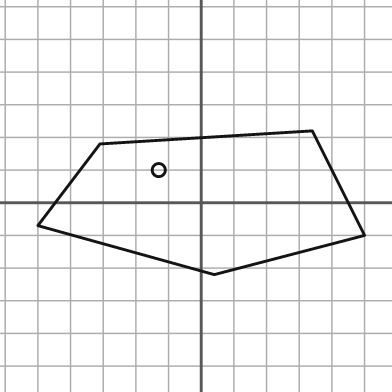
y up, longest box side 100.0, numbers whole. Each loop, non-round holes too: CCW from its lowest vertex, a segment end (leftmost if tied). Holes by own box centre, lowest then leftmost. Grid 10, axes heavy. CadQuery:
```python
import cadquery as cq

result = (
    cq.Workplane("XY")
    .moveTo(4.0, -22.0)
    .lineTo(50.0, -10.0)
    .lineTo(34.0, 22.0)
    .lineTo(-31.0, 18.0)
    .lineTo(-50.0, -7.0)
    .close()
    .moveTo(-13.0, 10.0)
    .circle(2.0)
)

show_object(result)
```